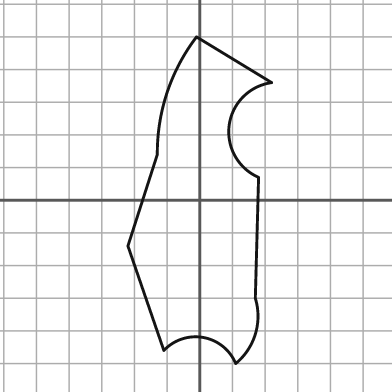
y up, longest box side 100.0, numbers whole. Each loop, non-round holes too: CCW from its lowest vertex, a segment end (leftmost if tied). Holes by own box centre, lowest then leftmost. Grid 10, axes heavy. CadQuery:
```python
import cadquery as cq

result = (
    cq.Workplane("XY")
    .moveTo(11.0, -50.0)
    .threePointArc((17.0, -41.0), (17.0, -30.0))
    .lineTo(18.0, 7.0)
    .threePointArc((9.0, 23.0), (22.0, 36.0))
    .lineTo(-1.0, 50.0)
    .threePointArc((-10.0, 33.0), (-13.0, 14.0))
    .lineTo(-22.0, -14.0)
    .lineTo(-11.0, -46.0)
    .threePointArc((1.0, -42.0), (11.0, -50.0))
    .close()
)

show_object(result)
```